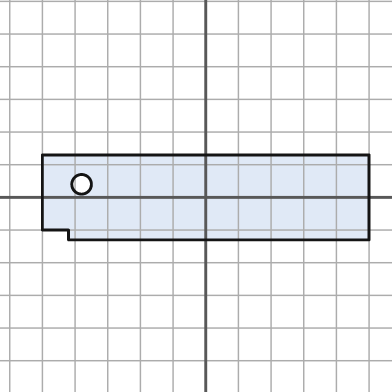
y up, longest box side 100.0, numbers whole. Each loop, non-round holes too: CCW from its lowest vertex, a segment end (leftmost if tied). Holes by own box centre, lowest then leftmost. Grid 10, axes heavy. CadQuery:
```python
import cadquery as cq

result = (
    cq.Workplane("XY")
    .moveTo(-42.0, -13.0)
    .lineTo(50.0, -13.0)
    .lineTo(50.0, 13.0)
    .lineTo(-50.0, 13.0)
    .lineTo(-50.0, -10.0)
    .lineTo(-42.0, -10.0)
    .close()
    .moveTo(-38.0, 4.0)
    .circle(3.0)
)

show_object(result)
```